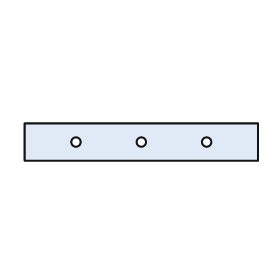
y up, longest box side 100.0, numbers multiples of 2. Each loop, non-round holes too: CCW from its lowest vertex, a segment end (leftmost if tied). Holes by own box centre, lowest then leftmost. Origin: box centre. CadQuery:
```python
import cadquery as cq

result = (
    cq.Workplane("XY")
    .moveTo(-50.0, -8.0)
    .lineTo(50.0, -8.0)
    .lineTo(50.0, 8.0)
    .lineTo(-50.0, 8.0)
    .close()
    .moveTo(-28.0, 0.0)
    .circle(2.0)
    .moveTo(0.0, 0.0)
    .circle(2.0)
    .moveTo(28.0, 0.0)
    .circle(2.0)
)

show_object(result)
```